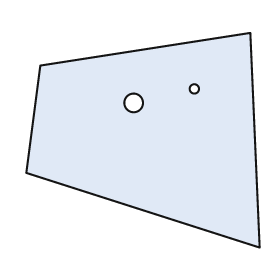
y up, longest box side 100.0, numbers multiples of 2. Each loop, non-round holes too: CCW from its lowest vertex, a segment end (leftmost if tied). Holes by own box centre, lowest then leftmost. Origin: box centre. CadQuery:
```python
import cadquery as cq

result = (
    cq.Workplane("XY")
    .moveTo(50.0, -46.0)
    .lineTo(46.0, 46.0)
    .lineTo(-44.0, 32.0)
    .lineTo(-50.0, -14.0)
    .close()
    .moveTo(-4.0, 16.0)
    .circle(4.0)
    .moveTo(22.0, 22.0)
    .circle(2.0)
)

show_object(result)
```